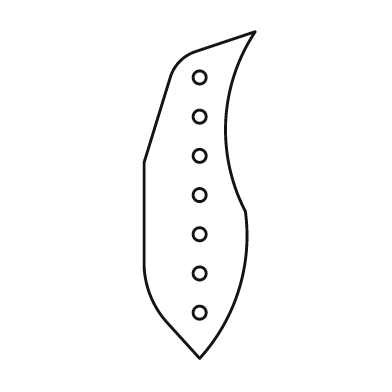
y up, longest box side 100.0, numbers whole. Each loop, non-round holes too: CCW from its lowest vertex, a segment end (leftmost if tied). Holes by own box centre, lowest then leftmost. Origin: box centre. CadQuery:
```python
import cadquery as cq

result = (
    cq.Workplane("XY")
    .moveTo(0.0, -50.0)
    .threePointArc((12.0, -29.0), (14.0, -5.0))
    .threePointArc((8.0, 23.0), (17.0, 50.0))
    .lineTo(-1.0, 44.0)
    .threePointArc((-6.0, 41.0), (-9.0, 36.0))
    .lineTo(-17.0, 10.0)
    .lineTo(-17.0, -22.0)
    .threePointArc((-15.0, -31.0), (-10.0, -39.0))
    .close()
    .moveTo(0.0, -36.0)
    .circle(2.0)
    .moveTo(0.0, -24.0)
    .circle(2.0)
    .moveTo(0.0, -12.0)
    .circle(2.0)
    .moveTo(0.0, 0.0)
    .circle(2.0)
    .moveTo(0.0, 12.0)
    .circle(2.0)
    .moveTo(0.0, 24.0)
    .circle(2.0)
    .moveTo(0.0, 36.0)
    .circle(2.0)
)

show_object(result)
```